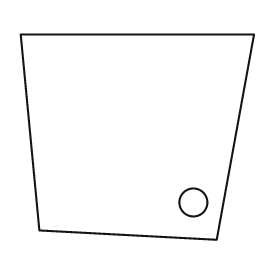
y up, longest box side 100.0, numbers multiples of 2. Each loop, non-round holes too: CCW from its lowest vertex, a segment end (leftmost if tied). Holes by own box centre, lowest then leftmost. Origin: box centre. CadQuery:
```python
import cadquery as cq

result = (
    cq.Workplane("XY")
    .moveTo(34.0, -44.0)
    .lineTo(50.0, 44.0)
    .lineTo(-50.0, 44.0)
    .lineTo(-42.0, -40.0)
    .close()
    .moveTo(24.0, -28.0)
    .circle(6.0)
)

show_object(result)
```